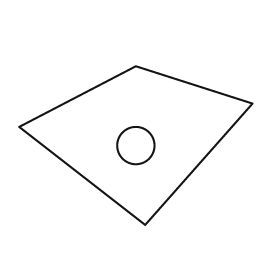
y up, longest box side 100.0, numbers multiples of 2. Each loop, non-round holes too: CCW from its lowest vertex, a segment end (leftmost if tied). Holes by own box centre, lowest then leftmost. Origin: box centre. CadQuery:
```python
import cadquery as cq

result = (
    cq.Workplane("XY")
    .moveTo(4.0, -34.0)
    .lineTo(50.0, 18.0)
    .lineTo(0.0, 34.0)
    .lineTo(-50.0, 8.0)
    .close()
    .moveTo(0.0, 0.0)
    .circle(8.0)
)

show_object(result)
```